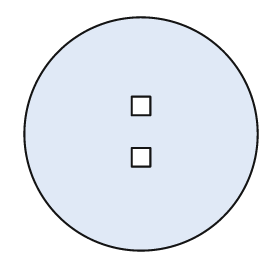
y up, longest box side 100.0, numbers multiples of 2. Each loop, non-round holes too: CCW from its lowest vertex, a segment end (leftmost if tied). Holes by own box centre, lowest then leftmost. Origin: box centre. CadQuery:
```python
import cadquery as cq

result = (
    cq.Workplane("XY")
    .moveTo(0.0, 0.0)
    .circle(50.0)
    .moveTo(-4.0, -14.0)
    .lineTo(4.0, -14.0)
    .lineTo(4.0, -6.0)
    .lineTo(-4.0, -6.0)
    .close()
    .moveTo(-4.0, 8.0)
    .lineTo(4.0, 8.0)
    .lineTo(4.0, 16.0)
    .lineTo(-4.0, 16.0)
    .close()
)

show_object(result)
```